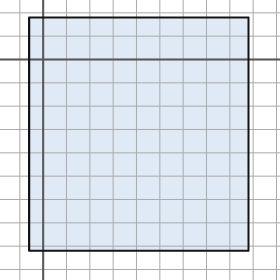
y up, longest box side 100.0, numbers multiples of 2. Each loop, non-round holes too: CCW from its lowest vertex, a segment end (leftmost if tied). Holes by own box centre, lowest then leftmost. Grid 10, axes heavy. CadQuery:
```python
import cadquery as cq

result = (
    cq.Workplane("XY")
    .moveTo(-6.0, -82.0)
    .lineTo(88.0, -82.0)
    .lineTo(88.0, 18.0)
    .lineTo(-6.0, 18.0)
    .close()
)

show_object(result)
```